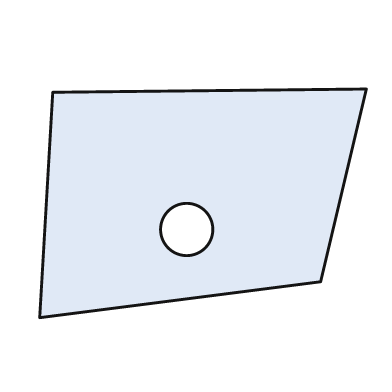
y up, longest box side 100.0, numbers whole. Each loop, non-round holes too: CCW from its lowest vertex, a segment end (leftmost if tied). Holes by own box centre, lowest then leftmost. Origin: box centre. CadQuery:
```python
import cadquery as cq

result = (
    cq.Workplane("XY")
    .moveTo(-50.0, -35.0)
    .lineTo(36.0, -24.0)
    .lineTo(50.0, 35.0)
    .lineTo(-46.0, 34.0)
    .close()
    .moveTo(-5.0, -8.0)
    .circle(8.0)
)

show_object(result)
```